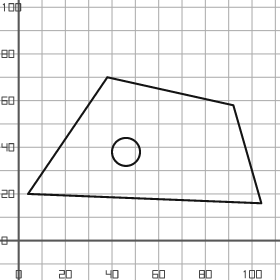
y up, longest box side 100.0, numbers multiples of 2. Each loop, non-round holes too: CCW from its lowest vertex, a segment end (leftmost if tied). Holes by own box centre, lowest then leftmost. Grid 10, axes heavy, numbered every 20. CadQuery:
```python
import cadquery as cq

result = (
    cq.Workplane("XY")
    .moveTo(104.0, 16.0)
    .lineTo(92.0, 58.0)
    .lineTo(38.0, 70.0)
    .lineTo(4.0, 20.0)
    .close()
    .moveTo(46.0, 38.0)
    .circle(6.0)
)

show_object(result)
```